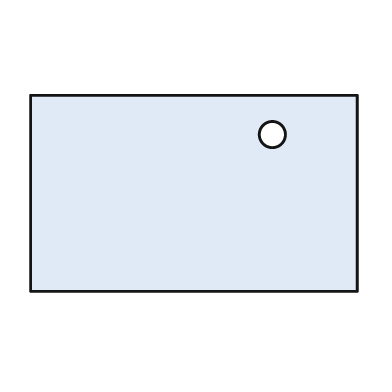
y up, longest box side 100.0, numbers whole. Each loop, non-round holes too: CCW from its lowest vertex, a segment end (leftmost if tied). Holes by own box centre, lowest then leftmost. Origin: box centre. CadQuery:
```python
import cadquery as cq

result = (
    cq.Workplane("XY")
    .moveTo(-50.0, -30.0)
    .lineTo(50.0, -30.0)
    .lineTo(50.0, 30.0)
    .lineTo(-50.0, 30.0)
    .close()
    .moveTo(24.0, 18.0)
    .circle(4.0)
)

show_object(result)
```